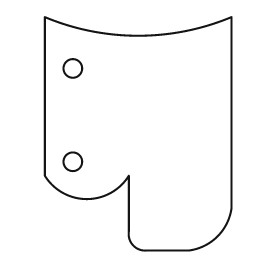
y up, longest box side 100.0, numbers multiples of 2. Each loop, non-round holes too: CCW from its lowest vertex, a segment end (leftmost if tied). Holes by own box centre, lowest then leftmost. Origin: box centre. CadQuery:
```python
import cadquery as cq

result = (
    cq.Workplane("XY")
    .moveTo(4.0, -50.0)
    .lineTo(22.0, -50.0)
    .threePointArc((34.0, -44.0), (40.0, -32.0))
    .lineTo(40.0, 50.0)
    .threePointArc((0.0, 42.0), (-40.0, 50.0))
    .lineTo(-40.0, -18.0)
    .threePointArc((-22.0, -28.0), (-4.0, -18.0))
    .lineTo(-4.0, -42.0)
    .threePointArc((-2.0, -48.0), (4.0, -50.0))
    .close()
    .moveTo(-28.0, -12.0)
    .circle(4.0)
    .moveTo(-28.0, 28.0)
    .circle(4.0)
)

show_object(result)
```